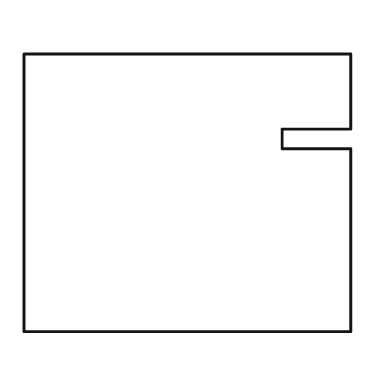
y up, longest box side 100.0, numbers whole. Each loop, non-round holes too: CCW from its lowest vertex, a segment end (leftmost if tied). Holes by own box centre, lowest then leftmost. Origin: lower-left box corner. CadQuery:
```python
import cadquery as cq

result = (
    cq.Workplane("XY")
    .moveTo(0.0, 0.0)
    .lineTo(100.0, 0.0)
    .lineTo(100.0, 56.0)
    .lineTo(79.0, 56.0)
    .lineTo(79.0, 62.0)
    .lineTo(100.0, 62.0)
    .lineTo(100.0, 85.0)
    .lineTo(0.0, 85.0)
    .close()
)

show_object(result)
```